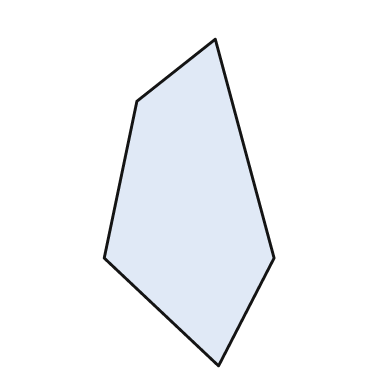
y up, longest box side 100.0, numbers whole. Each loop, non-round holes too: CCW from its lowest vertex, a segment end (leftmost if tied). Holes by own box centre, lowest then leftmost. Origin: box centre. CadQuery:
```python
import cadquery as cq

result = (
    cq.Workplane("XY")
    .moveTo(9.0, -50.0)
    .lineTo(26.0, -17.0)
    .lineTo(8.0, 50.0)
    .lineTo(-16.0, 31.0)
    .lineTo(-26.0, -17.0)
    .close()
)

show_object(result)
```